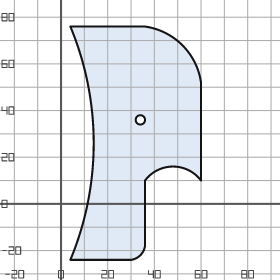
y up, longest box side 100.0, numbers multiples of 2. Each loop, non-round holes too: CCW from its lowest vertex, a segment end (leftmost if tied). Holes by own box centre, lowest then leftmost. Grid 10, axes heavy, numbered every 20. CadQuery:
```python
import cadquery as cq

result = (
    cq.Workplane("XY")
    .moveTo(4.0, -24.0)
    .lineTo(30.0, -24.0)
    .threePointArc((34.0, -22.0), (36.0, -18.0))
    .lineTo(36.0, 10.0)
    .threePointArc((48.0, 16.0), (60.0, 10.0))
    .lineTo(60.0, 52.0)
    .threePointArc((52.0, 68.0), (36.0, 76.0))
    .lineTo(4.0, 76.0)
    .threePointArc((14.0, 26.0), (4.0, -24.0))
    .close()
    .moveTo(34.0, 36.0)
    .circle(2.0)
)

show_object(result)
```